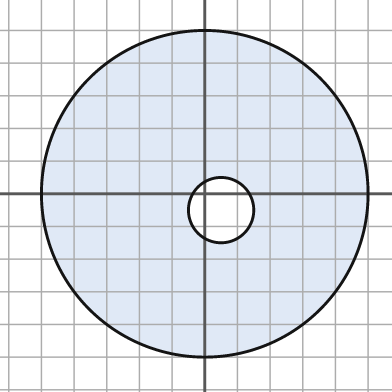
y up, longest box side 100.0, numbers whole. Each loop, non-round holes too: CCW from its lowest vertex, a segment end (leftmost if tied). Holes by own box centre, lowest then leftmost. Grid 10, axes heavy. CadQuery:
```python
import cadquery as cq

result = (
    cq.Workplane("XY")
    .moveTo(0.0, 0.0)
    .circle(50.0)
    .moveTo(5.0, -5.0)
    .circle(10.0)
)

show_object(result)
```